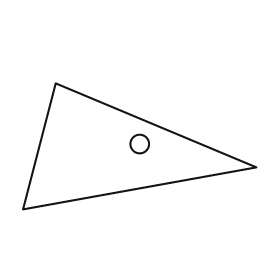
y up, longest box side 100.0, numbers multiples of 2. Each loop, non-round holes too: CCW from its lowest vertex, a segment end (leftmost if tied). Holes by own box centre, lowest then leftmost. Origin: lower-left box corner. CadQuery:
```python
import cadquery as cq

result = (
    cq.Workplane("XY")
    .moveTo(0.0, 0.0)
    .lineTo(100.0, 18.0)
    .lineTo(14.0, 54.0)
    .close()
    .moveTo(50.0, 28.0)
    .circle(4.0)
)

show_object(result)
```